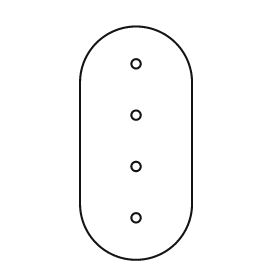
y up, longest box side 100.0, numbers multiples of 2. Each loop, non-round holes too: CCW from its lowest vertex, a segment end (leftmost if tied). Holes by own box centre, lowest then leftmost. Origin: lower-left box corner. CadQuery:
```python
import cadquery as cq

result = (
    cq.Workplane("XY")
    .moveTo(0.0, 24.0)
    .threePointArc((24.0, 0.0), (48.0, 24.0))
    .lineTo(48.0, 76.0)
    .threePointArc((24.0, 100.0), (0.0, 76.0))
    .close()
    .moveTo(24.0, 18.0)
    .circle(2.0)
    .moveTo(24.0, 40.0)
    .circle(2.0)
    .moveTo(24.0, 62.0)
    .circle(2.0)
    .moveTo(24.0, 84.0)
    .circle(2.0)
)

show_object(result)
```